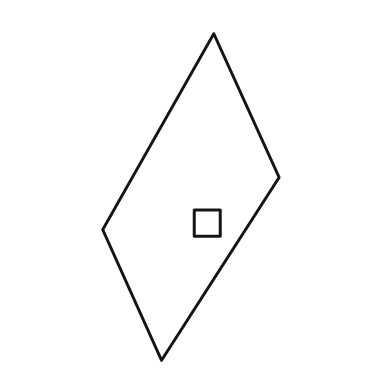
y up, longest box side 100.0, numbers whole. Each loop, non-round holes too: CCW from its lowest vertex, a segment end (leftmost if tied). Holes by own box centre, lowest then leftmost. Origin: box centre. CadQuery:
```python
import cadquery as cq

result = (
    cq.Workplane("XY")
    .moveTo(-9.0, -50.0)
    .lineTo(27.0, 6.0)
    .lineTo(7.0, 50.0)
    .lineTo(-27.0, -10.0)
    .close()
    .moveTo(1.0, -12.0)
    .lineTo(9.0, -12.0)
    .lineTo(9.0, -4.0)
    .lineTo(1.0, -4.0)
    .close()
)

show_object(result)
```